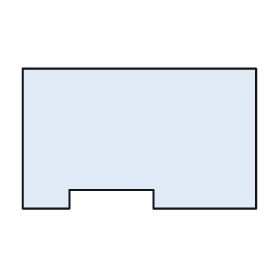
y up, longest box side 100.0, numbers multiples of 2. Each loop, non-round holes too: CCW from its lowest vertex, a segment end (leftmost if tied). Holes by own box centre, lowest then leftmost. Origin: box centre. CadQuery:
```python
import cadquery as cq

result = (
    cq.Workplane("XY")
    .moveTo(-50.0, -30.0)
    .lineTo(-30.0, -30.0)
    .lineTo(-30.0, -22.0)
    .lineTo(6.0, -22.0)
    .lineTo(6.0, -30.0)
    .lineTo(50.0, -30.0)
    .lineTo(50.0, 30.0)
    .lineTo(-50.0, 30.0)
    .close()
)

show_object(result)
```